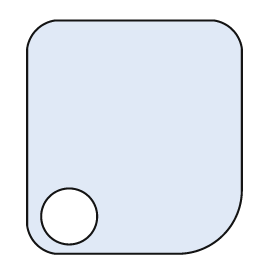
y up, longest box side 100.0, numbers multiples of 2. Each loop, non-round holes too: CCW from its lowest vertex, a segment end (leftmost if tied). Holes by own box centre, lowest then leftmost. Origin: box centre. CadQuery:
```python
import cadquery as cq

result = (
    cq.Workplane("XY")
    .moveTo(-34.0, -50.0)
    .lineTo(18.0, -50.0)
    .threePointArc((38.0, -42.0), (46.0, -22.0))
    .lineTo(46.0, 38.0)
    .threePointArc((42.0, 46.0), (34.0, 50.0))
    .lineTo(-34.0, 50.0)
    .threePointArc((-42.0, 46.0), (-46.0, 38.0))
    .lineTo(-46.0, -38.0)
    .threePointArc((-42.0, -46.0), (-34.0, -50.0))
    .close()
    .moveTo(-28.0, -34.0)
    .circle(12.0)
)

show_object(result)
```